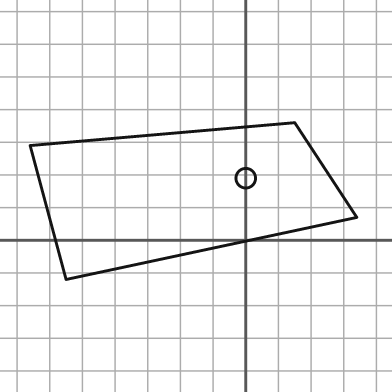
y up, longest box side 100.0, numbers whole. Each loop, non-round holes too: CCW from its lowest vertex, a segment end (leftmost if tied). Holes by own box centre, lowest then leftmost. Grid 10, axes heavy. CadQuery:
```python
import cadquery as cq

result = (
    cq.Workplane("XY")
    .moveTo(-55.0, -12.0)
    .lineTo(34.0, 7.0)
    .lineTo(15.0, 36.0)
    .lineTo(-66.0, 29.0)
    .close()
    .moveTo(0.0, 19.0)
    .circle(3.0)
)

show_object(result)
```